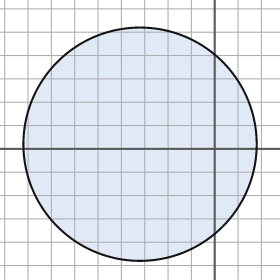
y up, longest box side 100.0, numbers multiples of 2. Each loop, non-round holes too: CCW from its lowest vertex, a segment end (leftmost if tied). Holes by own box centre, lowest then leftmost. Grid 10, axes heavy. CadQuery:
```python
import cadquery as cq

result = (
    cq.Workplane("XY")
    .moveTo(-32.0, 2.0)
    .circle(50.0)
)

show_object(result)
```